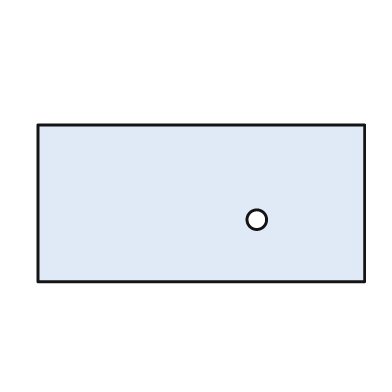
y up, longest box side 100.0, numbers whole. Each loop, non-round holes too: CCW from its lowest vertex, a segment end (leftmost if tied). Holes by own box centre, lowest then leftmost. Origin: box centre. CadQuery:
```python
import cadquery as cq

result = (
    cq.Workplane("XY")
    .moveTo(-50.0, -24.0)
    .lineTo(50.0, -24.0)
    .lineTo(50.0, 24.0)
    .lineTo(-50.0, 24.0)
    .close()
    .moveTo(17.0, -5.0)
    .circle(3.0)
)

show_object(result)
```